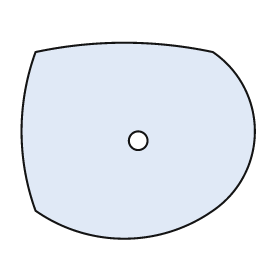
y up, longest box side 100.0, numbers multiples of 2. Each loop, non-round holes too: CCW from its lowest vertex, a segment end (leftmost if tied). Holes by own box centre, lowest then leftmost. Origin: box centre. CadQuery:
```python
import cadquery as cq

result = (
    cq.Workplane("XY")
    .moveTo(-44.0, -30.0)
    .threePointArc((-6.0, -42.0), (32.0, -30.0))
    .threePointArc((50.0, 4.0), (32.0, 38.0))
    .threePointArc((-6.0, 42.0), (-44.0, 38.0))
    .threePointArc((-50.0, 4.0), (-44.0, -30.0))
    .close()
    .moveTo(0.0, 0.0)
    .circle(4.0)
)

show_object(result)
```